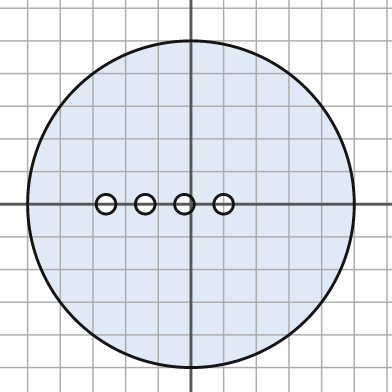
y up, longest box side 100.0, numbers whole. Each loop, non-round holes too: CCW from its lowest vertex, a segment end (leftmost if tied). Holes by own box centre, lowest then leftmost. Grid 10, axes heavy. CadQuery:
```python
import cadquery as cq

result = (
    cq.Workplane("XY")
    .moveTo(0.0, 0.0)
    .circle(50.0)
    .moveTo(-26.0, 0.0)
    .circle(3.0)
    .moveTo(-14.0, 0.0)
    .circle(3.0)
    .moveTo(-2.0, 0.0)
    .circle(3.0)
    .moveTo(10.0, 0.0)
    .circle(3.0)
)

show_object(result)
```